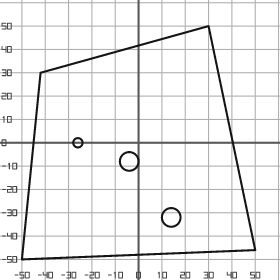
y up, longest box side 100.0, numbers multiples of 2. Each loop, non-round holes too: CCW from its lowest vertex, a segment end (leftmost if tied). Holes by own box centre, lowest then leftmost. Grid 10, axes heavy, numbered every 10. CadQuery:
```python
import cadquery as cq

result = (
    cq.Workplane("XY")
    .moveTo(-50.0, -50.0)
    .lineTo(50.0, -46.0)
    .lineTo(30.0, 50.0)
    .lineTo(-42.0, 30.0)
    .close()
    .moveTo(14.0, -32.0)
    .circle(4.0)
    .moveTo(-4.0, -8.0)
    .circle(4.0)
    .moveTo(-26.0, 0.0)
    .circle(2.0)
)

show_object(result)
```